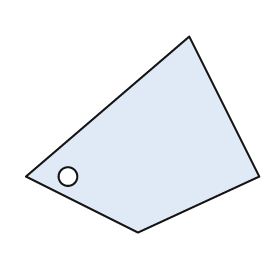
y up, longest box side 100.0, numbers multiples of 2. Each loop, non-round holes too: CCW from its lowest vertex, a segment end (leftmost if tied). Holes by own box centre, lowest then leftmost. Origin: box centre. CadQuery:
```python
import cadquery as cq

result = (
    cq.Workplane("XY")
    .moveTo(-2.0, -42.0)
    .lineTo(50.0, -18.0)
    .lineTo(20.0, 42.0)
    .lineTo(-50.0, -18.0)
    .close()
    .moveTo(-32.0, -18.0)
    .circle(4.0)
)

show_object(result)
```